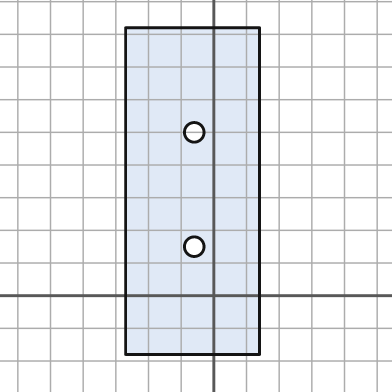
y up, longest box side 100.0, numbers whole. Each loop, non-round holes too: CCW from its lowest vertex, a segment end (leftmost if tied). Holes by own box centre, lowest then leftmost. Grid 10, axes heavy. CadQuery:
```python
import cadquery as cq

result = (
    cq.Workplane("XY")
    .moveTo(-27.0, -18.0)
    .lineTo(14.0, -18.0)
    .lineTo(14.0, 82.0)
    .lineTo(-27.0, 82.0)
    .close()
    .moveTo(-6.0, 15.0)
    .circle(3.0)
    .moveTo(-6.0, 50.0)
    .circle(3.0)
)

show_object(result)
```